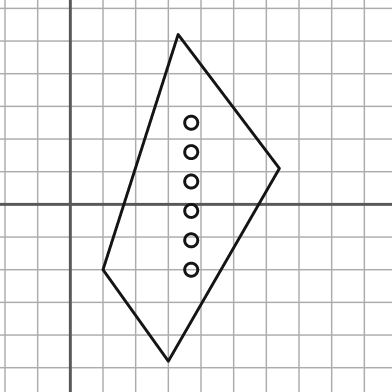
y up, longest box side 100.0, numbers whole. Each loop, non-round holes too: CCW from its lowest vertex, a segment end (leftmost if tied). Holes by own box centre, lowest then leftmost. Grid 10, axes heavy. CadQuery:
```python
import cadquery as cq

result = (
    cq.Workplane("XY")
    .moveTo(30.0, -48.0)
    .lineTo(64.0, 11.0)
    .lineTo(33.0, 52.0)
    .lineTo(10.0, -20.0)
    .close()
    .moveTo(37.0, -20.0)
    .circle(2.0)
    .moveTo(37.0, -11.0)
    .circle(2.0)
    .moveTo(37.0, -2.0)
    .circle(2.0)
    .moveTo(37.0, 7.0)
    .circle(2.0)
    .moveTo(37.0, 16.0)
    .circle(2.0)
    .moveTo(37.0, 25.0)
    .circle(2.0)
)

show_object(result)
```